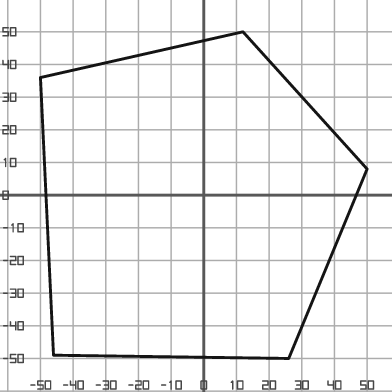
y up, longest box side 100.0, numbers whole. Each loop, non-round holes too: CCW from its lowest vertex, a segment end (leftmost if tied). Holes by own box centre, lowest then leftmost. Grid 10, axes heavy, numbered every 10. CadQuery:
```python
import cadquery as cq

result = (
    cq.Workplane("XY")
    .moveTo(26.0, -50.0)
    .lineTo(50.0, 8.0)
    .lineTo(12.0, 50.0)
    .lineTo(-50.0, 36.0)
    .lineTo(-46.0, -49.0)
    .close()
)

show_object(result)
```